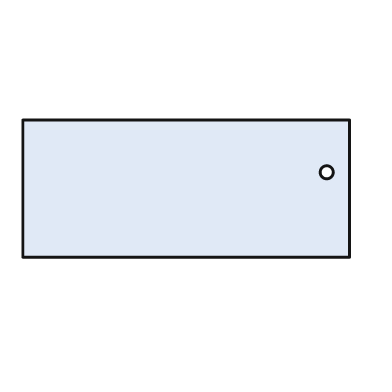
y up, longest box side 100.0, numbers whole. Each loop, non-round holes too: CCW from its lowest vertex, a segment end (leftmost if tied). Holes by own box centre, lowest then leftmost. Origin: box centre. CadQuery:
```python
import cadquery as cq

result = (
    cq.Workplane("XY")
    .moveTo(-50.0, -21.0)
    .lineTo(50.0, -21.0)
    .lineTo(50.0, 21.0)
    .lineTo(-50.0, 21.0)
    .close()
    .moveTo(43.0, 5.0)
    .circle(2.0)
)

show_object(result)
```